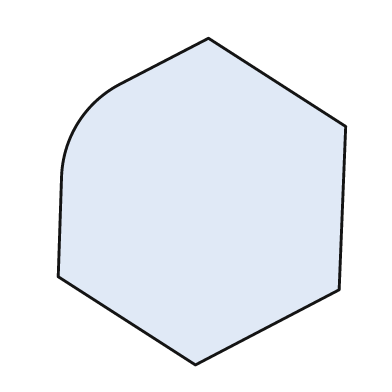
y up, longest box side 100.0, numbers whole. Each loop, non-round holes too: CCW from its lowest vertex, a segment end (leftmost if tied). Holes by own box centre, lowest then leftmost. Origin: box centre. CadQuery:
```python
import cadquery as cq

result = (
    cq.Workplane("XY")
    .moveTo(-2.0, -50.0)
    .lineTo(42.0, -27.0)
    .lineTo(44.0, 23.0)
    .lineTo(2.0, 50.0)
    .lineTo(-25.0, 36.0)
    .threePointArc((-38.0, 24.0), (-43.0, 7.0))
    .lineTo(-44.0, -23.0)
    .close()
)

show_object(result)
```